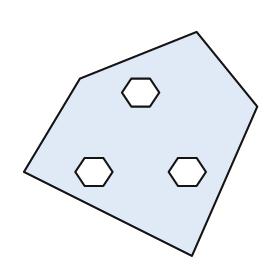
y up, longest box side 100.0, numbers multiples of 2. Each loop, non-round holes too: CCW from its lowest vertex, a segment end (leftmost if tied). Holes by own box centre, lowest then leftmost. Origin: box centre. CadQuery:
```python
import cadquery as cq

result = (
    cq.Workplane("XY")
    .moveTo(22.0, -48.0)
    .lineTo(50.0, 16.0)
    .lineTo(24.0, 48.0)
    .lineTo(-26.0, 28.0)
    .lineTo(-50.0, -12.0)
    .close()
    .moveTo(-24.0, -18.0)
    .lineTo(-16.0, -18.0)
    .lineTo(-12.0, -12.0)
    .lineTo(-16.0, -6.0)
    .lineTo(-24.0, -6.0)
    .lineTo(-28.0, -12.0)
    .close()
    .moveTo(16.0, -18.0)
    .lineTo(24.0, -18.0)
    .lineTo(28.0, -12.0)
    .lineTo(24.0, -6.0)
    .lineTo(16.0, -6.0)
    .lineTo(12.0, -12.0)
    .close()
    .moveTo(-4.0, 16.0)
    .lineTo(4.0, 16.0)
    .lineTo(8.0, 22.0)
    .lineTo(4.0, 28.0)
    .lineTo(-4.0, 28.0)
    .lineTo(-8.0, 22.0)
    .close()
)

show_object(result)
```